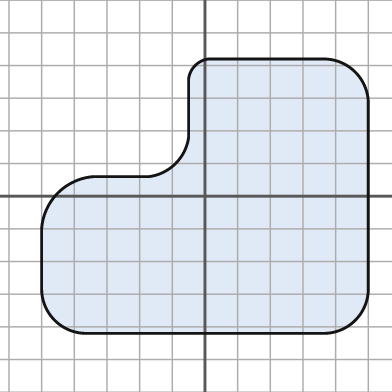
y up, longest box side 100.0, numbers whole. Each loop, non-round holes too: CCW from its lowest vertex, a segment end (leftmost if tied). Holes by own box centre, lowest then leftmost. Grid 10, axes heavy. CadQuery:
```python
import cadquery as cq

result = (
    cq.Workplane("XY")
    .moveTo(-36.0, -42.0)
    .lineTo(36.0, -42.0)
    .threePointArc((46.0, -38.0), (50.0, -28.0))
    .lineTo(50.0, 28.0)
    .threePointArc((46.0, 38.0), (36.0, 42.0))
    .lineTo(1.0, 42.0)
    .threePointArc((-3.0, 40.0), (-5.0, 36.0))
    .lineTo(-5.0, 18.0)
    .threePointArc((-9.0, 10.0), (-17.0, 6.0))
    .lineTo(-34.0, 6.0)
    .threePointArc((-45.0, 1.0), (-50.0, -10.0))
    .lineTo(-50.0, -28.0)
    .threePointArc((-46.0, -38.0), (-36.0, -42.0))
    .close()
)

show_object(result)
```